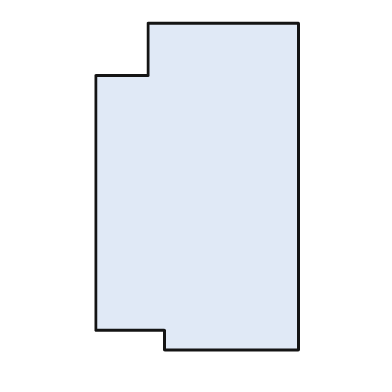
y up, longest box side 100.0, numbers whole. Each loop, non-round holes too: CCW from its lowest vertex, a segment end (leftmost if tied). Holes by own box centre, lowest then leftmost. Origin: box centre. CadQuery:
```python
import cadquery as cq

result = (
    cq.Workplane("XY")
    .moveTo(-10.0, -50.0)
    .lineTo(31.0, -50.0)
    .lineTo(31.0, 50.0)
    .lineTo(-15.0, 50.0)
    .lineTo(-15.0, 34.0)
    .lineTo(-31.0, 34.0)
    .lineTo(-31.0, -44.0)
    .lineTo(-10.0, -44.0)
    .close()
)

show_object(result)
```